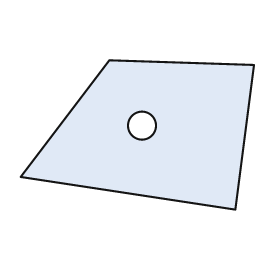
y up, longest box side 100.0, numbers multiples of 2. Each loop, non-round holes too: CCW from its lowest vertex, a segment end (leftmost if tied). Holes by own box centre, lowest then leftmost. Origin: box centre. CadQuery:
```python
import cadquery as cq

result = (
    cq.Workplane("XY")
    .moveTo(42.0, -32.0)
    .lineTo(50.0, 30.0)
    .lineTo(-12.0, 32.0)
    .lineTo(-50.0, -18.0)
    .close()
    .moveTo(2.0, 4.0)
    .circle(6.0)
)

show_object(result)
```